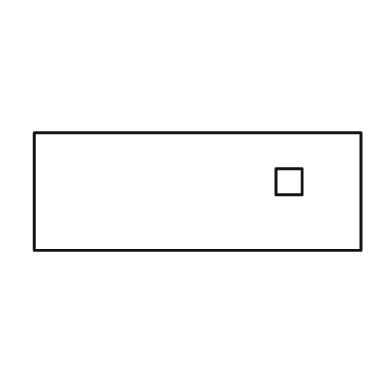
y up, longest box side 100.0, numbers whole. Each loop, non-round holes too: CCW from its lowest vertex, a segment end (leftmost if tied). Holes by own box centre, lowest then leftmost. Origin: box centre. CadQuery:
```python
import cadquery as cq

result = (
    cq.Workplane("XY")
    .moveTo(-50.0, -18.0)
    .lineTo(50.0, -18.0)
    .lineTo(50.0, 18.0)
    .lineTo(-50.0, 18.0)
    .close()
    .moveTo(24.0, -1.0)
    .lineTo(32.0, -1.0)
    .lineTo(32.0, 7.0)
    .lineTo(24.0, 7.0)
    .close()
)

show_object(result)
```